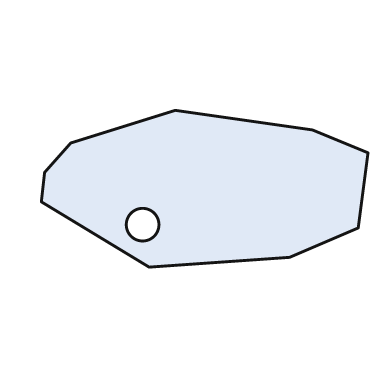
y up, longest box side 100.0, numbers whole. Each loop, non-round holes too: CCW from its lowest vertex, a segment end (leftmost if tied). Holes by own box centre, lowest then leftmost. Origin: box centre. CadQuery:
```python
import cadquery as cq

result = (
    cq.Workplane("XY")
    .moveTo(-17.0, -24.0)
    .lineTo(26.0, -21.0)
    .lineTo(47.0, -12.0)
    .lineTo(50.0, 11.0)
    .lineTo(33.0, 18.0)
    .lineTo(-9.0, 24.0)
    .lineTo(-41.0, 14.0)
    .lineTo(-49.0, 5.0)
    .lineTo(-50.0, -4.0)
    .close()
    .moveTo(-19.0, -11.0)
    .circle(5.0)
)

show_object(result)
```